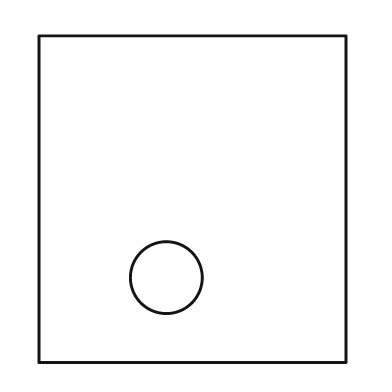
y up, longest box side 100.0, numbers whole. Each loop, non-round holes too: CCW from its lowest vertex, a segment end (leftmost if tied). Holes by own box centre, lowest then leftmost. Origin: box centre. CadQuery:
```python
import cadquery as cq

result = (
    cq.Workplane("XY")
    .moveTo(-47.0, -50.0)
    .lineTo(47.0, -50.0)
    .lineTo(47.0, 50.0)
    .lineTo(-47.0, 50.0)
    .close()
    .moveTo(-8.0, -24.0)
    .circle(11.0)
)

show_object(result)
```